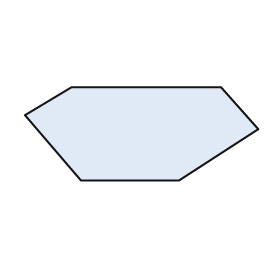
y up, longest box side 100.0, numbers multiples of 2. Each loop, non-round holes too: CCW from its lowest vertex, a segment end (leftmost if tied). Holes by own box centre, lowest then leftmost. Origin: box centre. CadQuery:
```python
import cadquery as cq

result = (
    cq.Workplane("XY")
    .moveTo(-26.0, -20.0)
    .lineTo(16.0, -20.0)
    .lineTo(50.0, 2.0)
    .lineTo(34.0, 20.0)
    .lineTo(-30.0, 20.0)
    .lineTo(-50.0, 8.0)
    .close()
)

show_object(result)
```